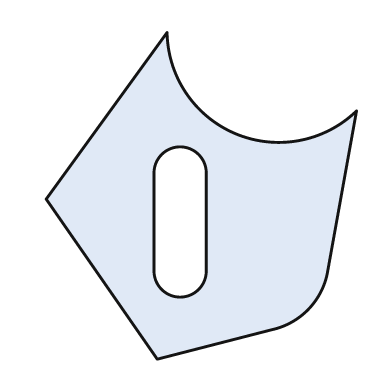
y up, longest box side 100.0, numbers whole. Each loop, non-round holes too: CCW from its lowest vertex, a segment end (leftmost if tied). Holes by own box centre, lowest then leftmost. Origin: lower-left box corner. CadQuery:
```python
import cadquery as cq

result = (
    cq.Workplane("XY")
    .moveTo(34.0, 0.0)
    .lineTo(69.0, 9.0)
    .threePointArc((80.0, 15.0), (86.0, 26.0))
    .lineTo(95.0, 76.0)
    .threePointArc((58.0, 69.0), (37.0, 100.0))
    .lineTo(0.0, 49.0)
    .close()
    .moveTo(33.0, 27.0)
    .threePointArc((41.0, 19.0), (49.0, 27.0))
    .lineTo(49.0, 57.0)
    .threePointArc((41.0, 65.0), (33.0, 57.0))
    .close()
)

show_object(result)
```